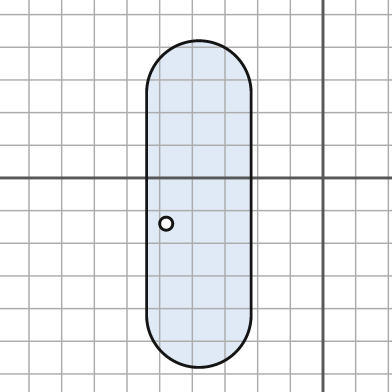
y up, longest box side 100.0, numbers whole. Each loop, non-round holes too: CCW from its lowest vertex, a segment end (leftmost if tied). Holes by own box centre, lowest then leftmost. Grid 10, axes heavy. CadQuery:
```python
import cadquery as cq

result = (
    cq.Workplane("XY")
    .moveTo(-54.0, -42.0)
    .threePointArc((-38.0, -58.0), (-22.0, -42.0))
    .lineTo(-22.0, 26.0)
    .threePointArc((-38.0, 42.0), (-54.0, 26.0))
    .close()
    .moveTo(-48.0, -14.0)
    .circle(2.0)
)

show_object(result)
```